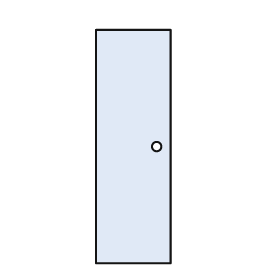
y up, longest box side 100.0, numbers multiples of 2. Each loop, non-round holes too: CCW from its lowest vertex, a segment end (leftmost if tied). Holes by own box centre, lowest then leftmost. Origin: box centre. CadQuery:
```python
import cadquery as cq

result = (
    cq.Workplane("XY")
    .moveTo(-16.0, -50.0)
    .lineTo(16.0, -50.0)
    .lineTo(16.0, 50.0)
    .lineTo(-16.0, 50.0)
    .close()
    .moveTo(10.0, 0.0)
    .circle(2.0)
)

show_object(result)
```